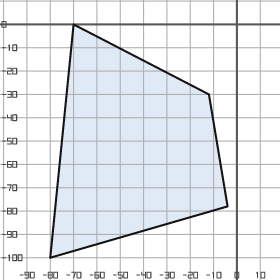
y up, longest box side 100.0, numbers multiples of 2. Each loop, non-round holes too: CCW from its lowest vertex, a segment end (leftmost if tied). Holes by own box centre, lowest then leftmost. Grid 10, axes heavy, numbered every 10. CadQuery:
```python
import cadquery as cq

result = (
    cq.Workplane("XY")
    .moveTo(-80.0, -100.0)
    .lineTo(-4.0, -78.0)
    .lineTo(-12.0, -30.0)
    .lineTo(-70.0, 0.0)
    .close()
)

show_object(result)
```